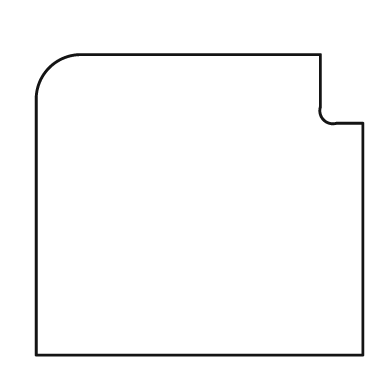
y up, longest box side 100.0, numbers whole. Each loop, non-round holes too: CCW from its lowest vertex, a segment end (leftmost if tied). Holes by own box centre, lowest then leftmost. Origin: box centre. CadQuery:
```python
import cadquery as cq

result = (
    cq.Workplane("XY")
    .moveTo(-50.0, -46.0)
    .lineTo(50.0, -46.0)
    .lineTo(50.0, 25.0)
    .lineTo(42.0, 25.0)
    .threePointArc((38.0, 26.0), (37.0, 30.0))
    .lineTo(37.0, 46.0)
    .lineTo(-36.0, 46.0)
    .threePointArc((-46.0, 42.0), (-50.0, 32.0))
    .close()
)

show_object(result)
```